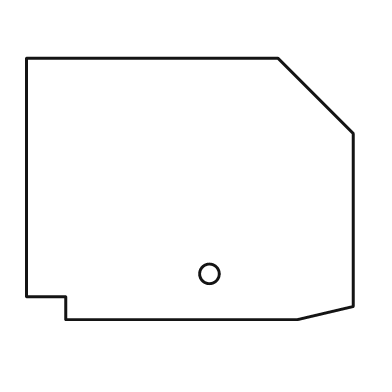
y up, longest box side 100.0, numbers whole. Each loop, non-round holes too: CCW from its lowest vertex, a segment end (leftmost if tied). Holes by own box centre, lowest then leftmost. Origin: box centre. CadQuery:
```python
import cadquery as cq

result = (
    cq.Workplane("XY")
    .moveTo(-38.0, -40.0)
    .lineTo(33.0, -40.0)
    .lineTo(50.0, -36.0)
    .lineTo(50.0, 17.0)
    .lineTo(27.0, 40.0)
    .lineTo(-50.0, 40.0)
    .lineTo(-50.0, -33.0)
    .lineTo(-38.0, -33.0)
    .close()
    .moveTo(6.0, -26.0)
    .circle(3.0)
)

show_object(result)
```